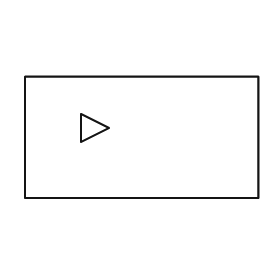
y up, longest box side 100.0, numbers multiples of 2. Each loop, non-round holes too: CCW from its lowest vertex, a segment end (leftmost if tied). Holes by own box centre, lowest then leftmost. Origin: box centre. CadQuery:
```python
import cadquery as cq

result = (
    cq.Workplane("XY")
    .moveTo(-50.0, -26.0)
    .lineTo(50.0, -26.0)
    .lineTo(50.0, 26.0)
    .lineTo(-50.0, 26.0)
    .close()
    .moveTo(-26.0, -2.0)
    .lineTo(-14.0, 4.0)
    .lineTo(-26.0, 10.0)
    .close()
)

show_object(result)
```